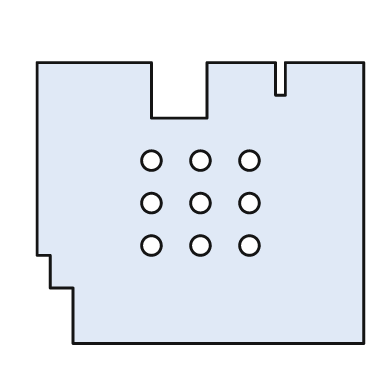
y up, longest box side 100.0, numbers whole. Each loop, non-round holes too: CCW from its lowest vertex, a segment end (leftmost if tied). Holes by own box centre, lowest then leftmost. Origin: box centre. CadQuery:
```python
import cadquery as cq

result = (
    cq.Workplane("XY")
    .moveTo(-39.0, -43.0)
    .lineTo(50.0, -43.0)
    .lineTo(50.0, 43.0)
    .lineTo(26.0, 43.0)
    .lineTo(26.0, 33.0)
    .lineTo(23.0, 33.0)
    .lineTo(23.0, 43.0)
    .lineTo(2.0, 43.0)
    .lineTo(2.0, 26.0)
    .lineTo(-15.0, 26.0)
    .lineTo(-15.0, 43.0)
    .lineTo(-50.0, 43.0)
    .lineTo(-50.0, -16.0)
    .lineTo(-46.0, -16.0)
    .lineTo(-46.0, -26.0)
    .lineTo(-39.0, -26.0)
    .close()
    .moveTo(-15.0, -13.0)
    .circle(3.0)
    .moveTo(0.0, -13.0)
    .circle(3.0)
    .moveTo(15.0, -13.0)
    .circle(3.0)
    .moveTo(-15.0, 0.0)
    .circle(3.0)
    .moveTo(0.0, 0.0)
    .circle(3.0)
    .moveTo(15.0, 0.0)
    .circle(3.0)
    .moveTo(-15.0, 13.0)
    .circle(3.0)
    .moveTo(0.0, 13.0)
    .circle(3.0)
    .moveTo(15.0, 13.0)
    .circle(3.0)
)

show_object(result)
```